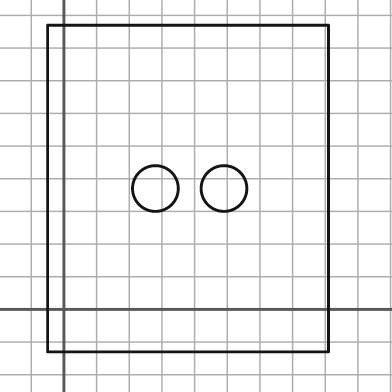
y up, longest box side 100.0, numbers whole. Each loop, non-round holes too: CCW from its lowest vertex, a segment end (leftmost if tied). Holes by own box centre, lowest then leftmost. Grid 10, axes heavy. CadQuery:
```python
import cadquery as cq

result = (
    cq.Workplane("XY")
    .moveTo(-5.0, -13.0)
    .lineTo(81.0, -13.0)
    .lineTo(81.0, 87.0)
    .lineTo(-5.0, 87.0)
    .close()
    .moveTo(28.0, 37.0)
    .circle(7.0)
    .moveTo(49.0, 37.0)
    .circle(7.0)
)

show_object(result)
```